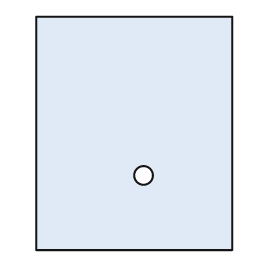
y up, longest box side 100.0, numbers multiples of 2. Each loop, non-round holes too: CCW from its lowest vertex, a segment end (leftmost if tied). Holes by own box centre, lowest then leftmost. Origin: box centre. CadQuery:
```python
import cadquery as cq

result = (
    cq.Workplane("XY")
    .moveTo(-42.0, -50.0)
    .lineTo(42.0, -50.0)
    .lineTo(42.0, 50.0)
    .lineTo(-42.0, 50.0)
    .close()
    .moveTo(4.0, -18.0)
    .circle(4.0)
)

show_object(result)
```